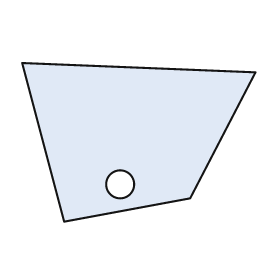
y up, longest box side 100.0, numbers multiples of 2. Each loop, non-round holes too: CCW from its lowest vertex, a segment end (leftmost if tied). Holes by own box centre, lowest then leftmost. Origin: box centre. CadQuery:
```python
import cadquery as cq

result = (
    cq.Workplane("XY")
    .moveTo(-32.0, -34.0)
    .lineTo(22.0, -24.0)
    .lineTo(50.0, 30.0)
    .lineTo(-50.0, 34.0)
    .close()
    .moveTo(-8.0, -18.0)
    .circle(6.0)
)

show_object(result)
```